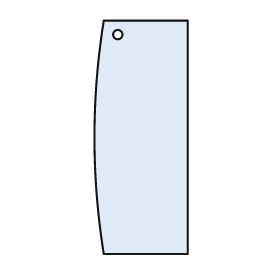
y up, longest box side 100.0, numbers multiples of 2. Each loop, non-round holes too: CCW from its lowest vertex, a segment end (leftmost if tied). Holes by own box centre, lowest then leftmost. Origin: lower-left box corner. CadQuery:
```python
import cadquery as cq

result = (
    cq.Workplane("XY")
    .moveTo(4.0, 0.0)
    .lineTo(40.0, 0.0)
    .lineTo(40.0, 100.0)
    .lineTo(4.0, 100.0)
    .threePointArc((0.0, 50.0), (4.0, 0.0))
    .close()
    .moveTo(10.0, 94.0)
    .circle(2.0)
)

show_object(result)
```